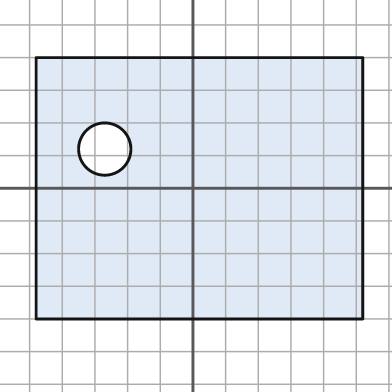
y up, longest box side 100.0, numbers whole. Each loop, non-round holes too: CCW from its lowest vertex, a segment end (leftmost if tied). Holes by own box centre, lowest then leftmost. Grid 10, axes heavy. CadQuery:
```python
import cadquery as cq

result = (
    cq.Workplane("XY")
    .moveTo(-48.0, -40.0)
    .lineTo(52.0, -40.0)
    .lineTo(52.0, 40.0)
    .lineTo(-48.0, 40.0)
    .close()
    .moveTo(-27.0, 12.0)
    .circle(8.0)
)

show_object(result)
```